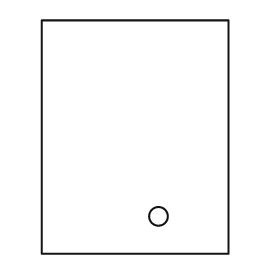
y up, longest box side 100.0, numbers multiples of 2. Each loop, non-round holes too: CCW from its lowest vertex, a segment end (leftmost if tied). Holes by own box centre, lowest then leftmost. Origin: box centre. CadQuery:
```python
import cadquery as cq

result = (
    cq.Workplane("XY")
    .moveTo(-40.0, -50.0)
    .lineTo(40.0, -50.0)
    .lineTo(40.0, 50.0)
    .lineTo(-40.0, 50.0)
    .close()
    .moveTo(10.0, -34.0)
    .circle(4.0)
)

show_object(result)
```